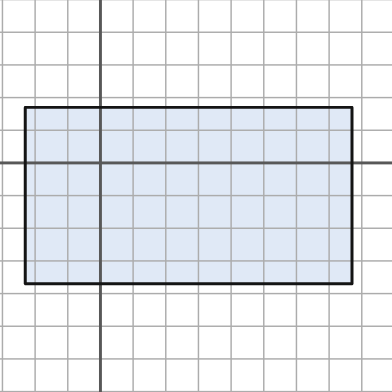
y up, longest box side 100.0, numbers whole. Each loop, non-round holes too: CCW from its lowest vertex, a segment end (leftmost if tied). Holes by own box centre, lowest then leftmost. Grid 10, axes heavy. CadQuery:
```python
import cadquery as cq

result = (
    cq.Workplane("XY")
    .moveTo(-23.0, -37.0)
    .lineTo(77.0, -37.0)
    .lineTo(77.0, 17.0)
    .lineTo(-23.0, 17.0)
    .close()
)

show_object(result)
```